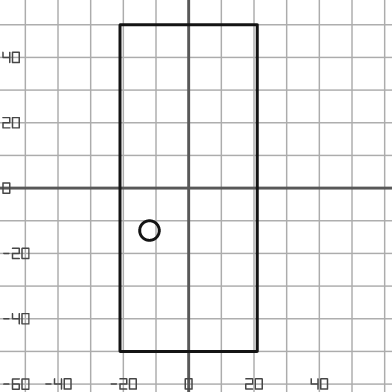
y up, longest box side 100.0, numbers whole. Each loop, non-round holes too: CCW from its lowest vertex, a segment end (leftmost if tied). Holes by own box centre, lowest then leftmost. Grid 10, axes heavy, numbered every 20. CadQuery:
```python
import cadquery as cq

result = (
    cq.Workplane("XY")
    .moveTo(-21.0, -50.0)
    .lineTo(21.0, -50.0)
    .lineTo(21.0, 50.0)
    .lineTo(-21.0, 50.0)
    .close()
    .moveTo(-12.0, -13.0)
    .circle(3.0)
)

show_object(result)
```